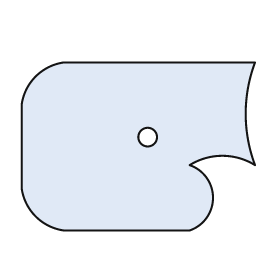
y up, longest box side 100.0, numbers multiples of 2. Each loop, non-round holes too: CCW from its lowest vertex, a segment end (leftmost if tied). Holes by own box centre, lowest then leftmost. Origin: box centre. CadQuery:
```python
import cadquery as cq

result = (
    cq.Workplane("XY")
    .moveTo(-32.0, -36.0)
    .lineTo(22.0, -36.0)
    .threePointArc((32.0, -22.0), (22.0, -8.0))
    .threePointArc((36.0, -4.0), (50.0, -8.0))
    .threePointArc((46.0, 14.0), (50.0, 36.0))
    .lineTo(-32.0, 36.0)
    .threePointArc((-44.0, 30.0), (-50.0, 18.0))
    .lineTo(-50.0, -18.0)
    .threePointArc((-44.0, -30.0), (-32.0, -36.0))
    .close()
    .moveTo(4.0, 4.0)
    .circle(4.0)
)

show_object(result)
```